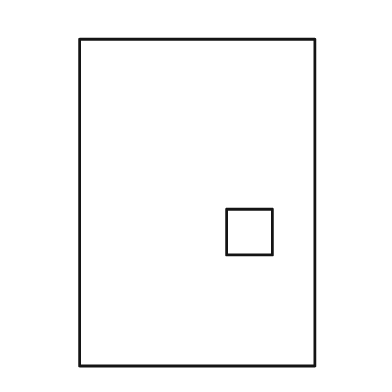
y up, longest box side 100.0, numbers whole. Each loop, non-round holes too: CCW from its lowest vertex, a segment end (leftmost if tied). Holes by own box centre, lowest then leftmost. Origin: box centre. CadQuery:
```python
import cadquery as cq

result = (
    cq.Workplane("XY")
    .moveTo(-36.0, -50.0)
    .lineTo(36.0, -50.0)
    .lineTo(36.0, 50.0)
    .lineTo(-36.0, 50.0)
    .close()
    .moveTo(9.0, -16.0)
    .lineTo(23.0, -16.0)
    .lineTo(23.0, -2.0)
    .lineTo(9.0, -2.0)
    .close()
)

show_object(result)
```